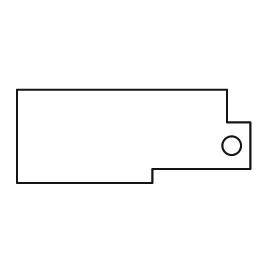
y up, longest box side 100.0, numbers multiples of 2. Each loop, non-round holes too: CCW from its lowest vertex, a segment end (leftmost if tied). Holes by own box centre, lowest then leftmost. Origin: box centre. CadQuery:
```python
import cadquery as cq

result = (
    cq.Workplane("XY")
    .moveTo(-50.0, -20.0)
    .lineTo(8.0, -20.0)
    .lineTo(8.0, -14.0)
    .lineTo(50.0, -14.0)
    .lineTo(50.0, 6.0)
    .lineTo(40.0, 6.0)
    .lineTo(40.0, 20.0)
    .lineTo(-50.0, 20.0)
    .close()
    .moveTo(42.0, -4.0)
    .circle(4.0)
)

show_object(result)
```